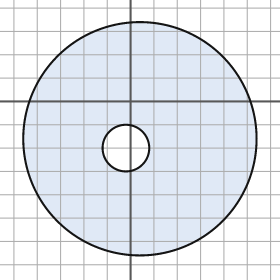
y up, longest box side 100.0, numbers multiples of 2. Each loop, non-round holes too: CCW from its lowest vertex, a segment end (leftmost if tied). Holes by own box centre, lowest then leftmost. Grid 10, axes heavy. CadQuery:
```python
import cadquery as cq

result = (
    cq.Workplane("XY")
    .moveTo(4.0, -16.0)
    .circle(50.0)
    .moveTo(-2.0, -20.0)
    .circle(10.0)
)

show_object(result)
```